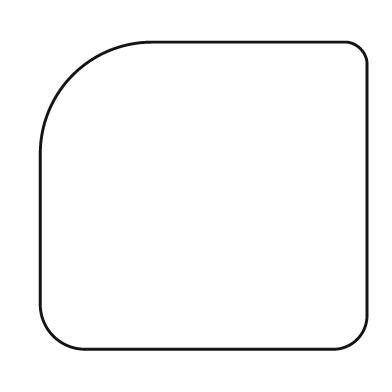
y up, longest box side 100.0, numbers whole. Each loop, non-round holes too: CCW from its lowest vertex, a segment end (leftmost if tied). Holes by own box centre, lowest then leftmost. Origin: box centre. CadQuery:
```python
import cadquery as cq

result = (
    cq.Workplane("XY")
    .moveTo(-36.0, -47.0)
    .lineTo(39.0, -47.0)
    .threePointArc((47.0, -44.0), (50.0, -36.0))
    .lineTo(50.0, 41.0)
    .threePointArc((48.0, 45.0), (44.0, 47.0))
    .lineTo(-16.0, 47.0)
    .threePointArc((-40.0, 37.0), (-50.0, 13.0))
    .lineTo(-50.0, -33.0)
    .threePointArc((-46.0, -43.0), (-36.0, -47.0))
    .close()
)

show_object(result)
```